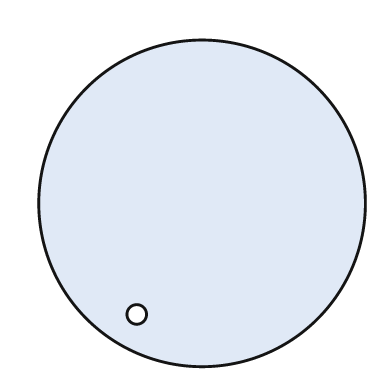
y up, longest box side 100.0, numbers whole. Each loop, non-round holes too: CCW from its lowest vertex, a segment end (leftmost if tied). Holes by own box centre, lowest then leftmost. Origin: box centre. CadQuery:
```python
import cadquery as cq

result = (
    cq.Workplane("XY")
    .moveTo(0.0, 0.0)
    .circle(50.0)
    .moveTo(-20.0, -34.0)
    .circle(3.0)
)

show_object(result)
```